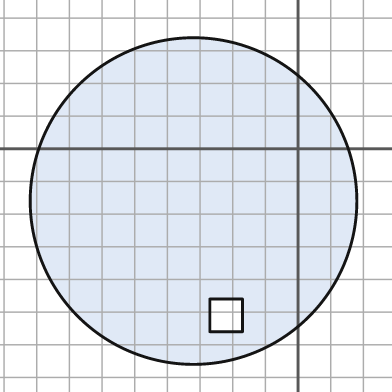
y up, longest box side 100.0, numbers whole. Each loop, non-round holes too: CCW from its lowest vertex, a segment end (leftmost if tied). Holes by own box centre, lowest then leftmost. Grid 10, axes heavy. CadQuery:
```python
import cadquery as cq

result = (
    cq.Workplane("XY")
    .moveTo(-32.0, -16.0)
    .circle(50.0)
    .moveTo(-27.0, -56.0)
    .lineTo(-17.0, -56.0)
    .lineTo(-17.0, -46.0)
    .lineTo(-27.0, -46.0)
    .close()
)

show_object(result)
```